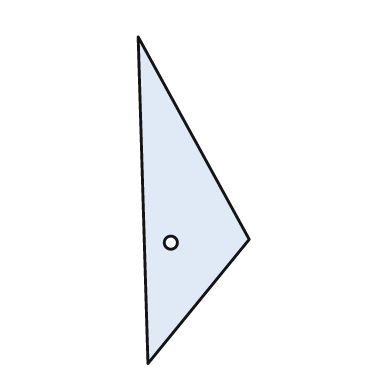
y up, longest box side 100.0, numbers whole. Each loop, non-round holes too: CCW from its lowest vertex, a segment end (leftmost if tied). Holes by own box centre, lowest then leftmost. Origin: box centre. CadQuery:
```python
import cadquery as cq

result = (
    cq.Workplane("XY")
    .moveTo(-14.0, -50.0)
    .lineTo(17.0, -12.0)
    .lineTo(-17.0, 50.0)
    .close()
    .moveTo(-7.0, -13.0)
    .circle(2.0)
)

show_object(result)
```